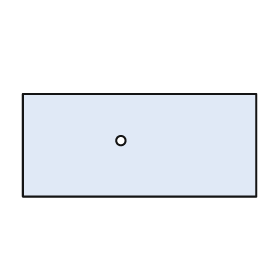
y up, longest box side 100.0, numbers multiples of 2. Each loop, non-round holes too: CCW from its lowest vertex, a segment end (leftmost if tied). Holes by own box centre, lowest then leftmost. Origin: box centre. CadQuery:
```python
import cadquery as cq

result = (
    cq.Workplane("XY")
    .moveTo(-50.0, -22.0)
    .lineTo(50.0, -22.0)
    .lineTo(50.0, 22.0)
    .lineTo(-50.0, 22.0)
    .close()
    .moveTo(-8.0, 2.0)
    .circle(2.0)
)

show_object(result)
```